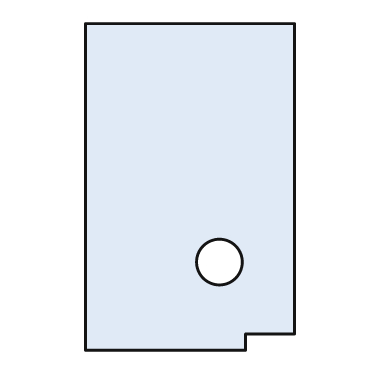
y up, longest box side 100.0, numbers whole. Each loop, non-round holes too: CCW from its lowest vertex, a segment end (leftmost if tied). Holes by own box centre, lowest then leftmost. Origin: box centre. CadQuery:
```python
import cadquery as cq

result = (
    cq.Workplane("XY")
    .moveTo(-32.0, -50.0)
    .lineTo(17.0, -50.0)
    .lineTo(17.0, -45.0)
    .lineTo(32.0, -45.0)
    .lineTo(32.0, 50.0)
    .lineTo(-32.0, 50.0)
    .close()
    .moveTo(9.0, -23.0)
    .circle(7.0)
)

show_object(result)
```